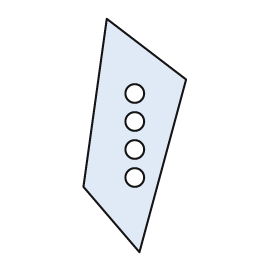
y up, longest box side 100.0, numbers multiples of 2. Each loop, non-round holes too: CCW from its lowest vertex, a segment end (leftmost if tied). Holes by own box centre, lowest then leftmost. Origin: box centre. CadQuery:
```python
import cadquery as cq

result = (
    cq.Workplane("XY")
    .moveTo(2.0, -50.0)
    .lineTo(22.0, 24.0)
    .lineTo(-12.0, 50.0)
    .lineTo(-22.0, -22.0)
    .close()
    .moveTo(0.0, -18.0)
    .circle(4.0)
    .moveTo(0.0, -6.0)
    .circle(4.0)
    .moveTo(0.0, 6.0)
    .circle(4.0)
    .moveTo(0.0, 18.0)
    .circle(4.0)
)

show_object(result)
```